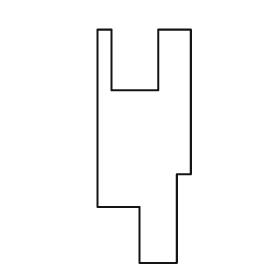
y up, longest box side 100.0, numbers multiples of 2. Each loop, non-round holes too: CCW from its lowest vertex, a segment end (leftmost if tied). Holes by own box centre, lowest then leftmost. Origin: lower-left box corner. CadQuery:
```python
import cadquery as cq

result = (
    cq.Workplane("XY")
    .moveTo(18.0, 0.0)
    .lineTo(34.0, 0.0)
    .lineTo(34.0, 38.0)
    .lineTo(40.0, 38.0)
    .lineTo(40.0, 100.0)
    .lineTo(26.0, 100.0)
    .lineTo(26.0, 74.0)
    .lineTo(6.0, 74.0)
    .lineTo(6.0, 100.0)
    .lineTo(0.0, 100.0)
    .lineTo(0.0, 24.0)
    .lineTo(18.0, 24.0)
    .close()
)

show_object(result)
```